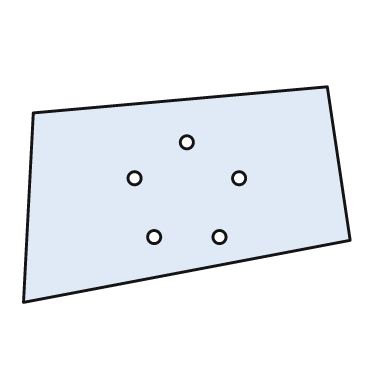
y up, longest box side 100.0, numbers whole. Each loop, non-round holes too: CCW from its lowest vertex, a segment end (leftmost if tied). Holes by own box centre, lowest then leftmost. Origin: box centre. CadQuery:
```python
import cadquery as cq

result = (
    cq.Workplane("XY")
    .moveTo(-50.0, -33.0)
    .lineTo(50.0, -14.0)
    .lineTo(43.0, 33.0)
    .lineTo(-47.0, 25.0)
    .close()
    .moveTo(-10.0, -13.0)
    .circle(2.0)
    .moveTo(10.0, -13.0)
    .circle(2.0)
    .moveTo(-16.0, 5.0)
    .circle(2.0)
    .moveTo(16.0, 5.0)
    .circle(2.0)
    .moveTo(0.0, 16.0)
    .circle(2.0)
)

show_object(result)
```